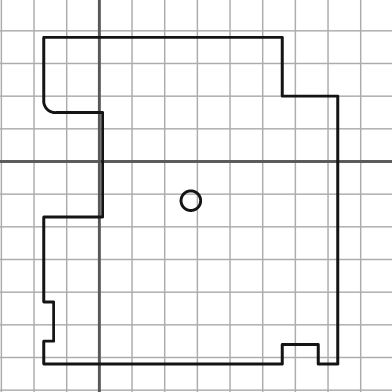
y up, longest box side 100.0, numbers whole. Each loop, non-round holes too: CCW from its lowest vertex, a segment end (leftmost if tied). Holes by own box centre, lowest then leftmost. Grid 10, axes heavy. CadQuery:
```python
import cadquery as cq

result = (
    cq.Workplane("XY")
    .moveTo(-17.0, -62.0)
    .lineTo(56.0, -62.0)
    .lineTo(56.0, -56.0)
    .lineTo(67.0, -56.0)
    .lineTo(67.0, -62.0)
    .lineTo(73.0, -62.0)
    .lineTo(73.0, 20.0)
    .lineTo(56.0, 20.0)
    .lineTo(56.0, 38.0)
    .lineTo(-17.0, 38.0)
    .lineTo(-17.0, 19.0)
    .threePointArc((-16.0, 16.0), (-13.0, 15.0))
    .lineTo(1.0, 15.0)
    .lineTo(1.0, -17.0)
    .lineTo(-17.0, -17.0)
    .lineTo(-17.0, -43.0)
    .lineTo(-14.0, -43.0)
    .lineTo(-14.0, -55.0)
    .lineTo(-17.0, -55.0)
    .close()
    .moveTo(28.0, -12.0)
    .circle(3.0)
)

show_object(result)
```